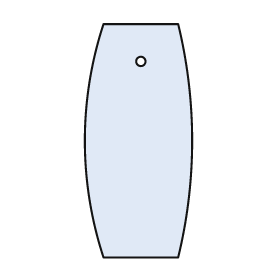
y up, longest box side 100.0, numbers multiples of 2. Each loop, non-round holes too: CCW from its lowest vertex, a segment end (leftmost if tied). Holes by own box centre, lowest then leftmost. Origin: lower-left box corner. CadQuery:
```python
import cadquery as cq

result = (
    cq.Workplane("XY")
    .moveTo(8.0, 0.0)
    .lineTo(40.0, 0.0)
    .threePointArc((46.0, 50.0), (40.0, 100.0))
    .lineTo(8.0, 100.0)
    .threePointArc((0.0, 50.0), (8.0, 0.0))
    .close()
    .moveTo(24.0, 84.0)
    .circle(2.0)
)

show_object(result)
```